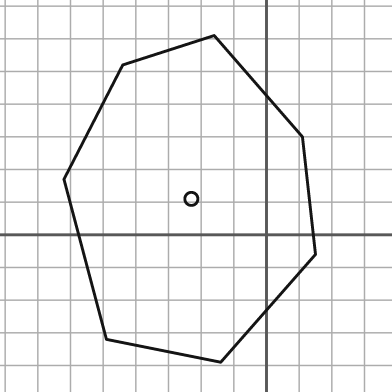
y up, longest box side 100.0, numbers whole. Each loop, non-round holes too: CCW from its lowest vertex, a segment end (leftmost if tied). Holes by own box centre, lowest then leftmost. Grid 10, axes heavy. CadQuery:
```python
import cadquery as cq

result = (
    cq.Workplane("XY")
    .moveTo(-14.0, -39.0)
    .lineTo(15.0, -6.0)
    .lineTo(11.0, 30.0)
    .lineTo(-16.0, 61.0)
    .lineTo(-44.0, 52.0)
    .lineTo(-62.0, 17.0)
    .lineTo(-49.0, -32.0)
    .close()
    .moveTo(-23.0, 11.0)
    .circle(2.0)
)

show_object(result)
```